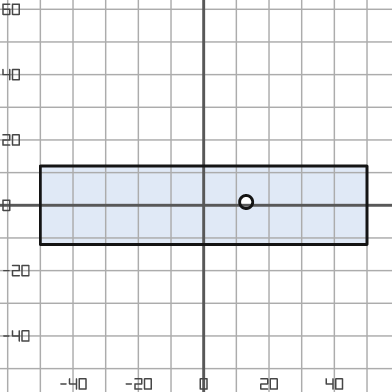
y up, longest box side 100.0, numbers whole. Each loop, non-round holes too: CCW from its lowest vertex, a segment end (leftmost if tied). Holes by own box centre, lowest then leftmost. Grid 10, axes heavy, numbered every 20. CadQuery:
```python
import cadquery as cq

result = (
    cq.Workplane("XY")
    .moveTo(-50.0, -12.0)
    .lineTo(50.0, -12.0)
    .lineTo(50.0, 12.0)
    .lineTo(-50.0, 12.0)
    .close()
    .moveTo(13.0, 1.0)
    .circle(2.0)
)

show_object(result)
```